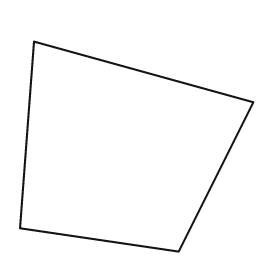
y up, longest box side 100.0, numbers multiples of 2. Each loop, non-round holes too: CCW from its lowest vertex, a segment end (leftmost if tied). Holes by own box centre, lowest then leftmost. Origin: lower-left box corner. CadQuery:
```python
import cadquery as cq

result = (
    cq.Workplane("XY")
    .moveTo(68.0, 0.0)
    .lineTo(100.0, 64.0)
    .lineTo(6.0, 90.0)
    .lineTo(0.0, 10.0)
    .close()
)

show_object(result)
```